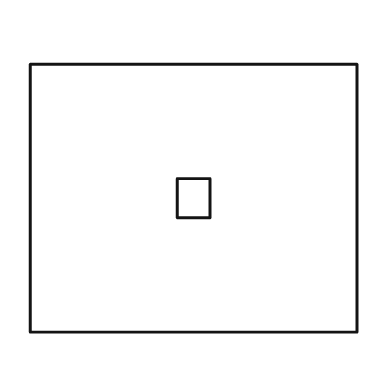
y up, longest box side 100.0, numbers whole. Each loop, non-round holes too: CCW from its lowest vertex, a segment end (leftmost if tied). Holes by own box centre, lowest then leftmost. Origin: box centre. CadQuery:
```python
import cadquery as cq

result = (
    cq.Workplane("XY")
    .moveTo(-50.0, -41.0)
    .lineTo(50.0, -41.0)
    .lineTo(50.0, 41.0)
    .lineTo(-50.0, 41.0)
    .close()
    .moveTo(-5.0, -6.0)
    .lineTo(5.0, -6.0)
    .lineTo(5.0, 6.0)
    .lineTo(-5.0, 6.0)
    .close()
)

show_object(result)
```